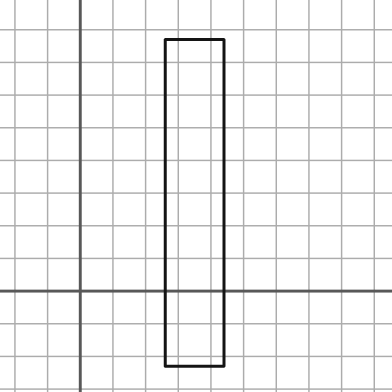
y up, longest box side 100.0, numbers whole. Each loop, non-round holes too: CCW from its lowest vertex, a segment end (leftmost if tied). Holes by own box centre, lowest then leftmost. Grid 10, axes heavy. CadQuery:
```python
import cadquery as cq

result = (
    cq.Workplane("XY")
    .moveTo(26.0, -23.0)
    .lineTo(44.0, -23.0)
    .lineTo(44.0, 77.0)
    .lineTo(26.0, 77.0)
    .close()
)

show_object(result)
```